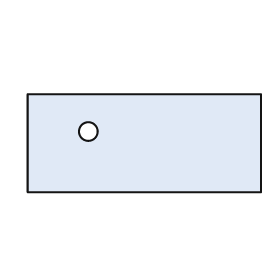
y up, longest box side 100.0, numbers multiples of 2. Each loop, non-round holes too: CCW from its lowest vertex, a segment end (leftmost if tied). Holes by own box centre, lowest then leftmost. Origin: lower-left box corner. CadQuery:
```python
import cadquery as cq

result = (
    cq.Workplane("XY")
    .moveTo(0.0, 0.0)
    .lineTo(100.0, 0.0)
    .lineTo(100.0, 42.0)
    .lineTo(0.0, 42.0)
    .close()
    .moveTo(26.0, 26.0)
    .circle(4.0)
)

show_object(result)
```